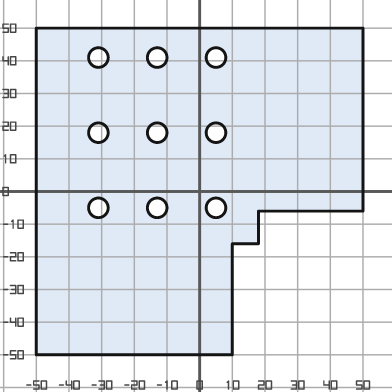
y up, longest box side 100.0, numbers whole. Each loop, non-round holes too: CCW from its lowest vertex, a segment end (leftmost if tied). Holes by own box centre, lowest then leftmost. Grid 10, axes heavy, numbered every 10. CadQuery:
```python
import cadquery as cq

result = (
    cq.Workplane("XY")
    .moveTo(-50.0, -50.0)
    .lineTo(10.0, -50.0)
    .lineTo(10.0, -16.0)
    .lineTo(18.0, -16.0)
    .lineTo(18.0, -6.0)
    .lineTo(50.0, -6.0)
    .lineTo(50.0, 50.0)
    .lineTo(-50.0, 50.0)
    .close()
    .moveTo(-31.0, -5.0)
    .circle(3.0)
    .moveTo(-13.0, -5.0)
    .circle(3.0)
    .moveTo(5.0, -5.0)
    .circle(3.0)
    .moveTo(-31.0, 18.0)
    .circle(3.0)
    .moveTo(-13.0, 18.0)
    .circle(3.0)
    .moveTo(5.0, 18.0)
    .circle(3.0)
    .moveTo(-31.0, 41.0)
    .circle(3.0)
    .moveTo(-13.0, 41.0)
    .circle(3.0)
    .moveTo(5.0, 41.0)
    .circle(3.0)
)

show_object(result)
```